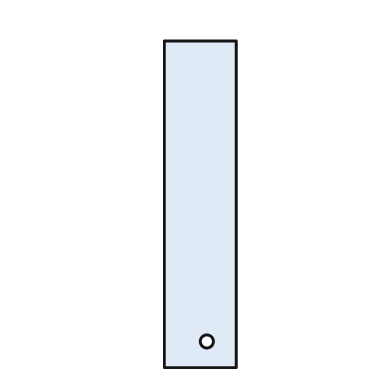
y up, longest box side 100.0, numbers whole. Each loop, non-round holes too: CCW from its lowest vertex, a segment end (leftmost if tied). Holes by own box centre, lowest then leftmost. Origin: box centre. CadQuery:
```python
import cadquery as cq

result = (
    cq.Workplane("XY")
    .moveTo(-11.0, -50.0)
    .lineTo(11.0, -50.0)
    .lineTo(11.0, 50.0)
    .lineTo(-11.0, 50.0)
    .close()
    .moveTo(2.0, -42.0)
    .circle(2.0)
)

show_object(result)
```